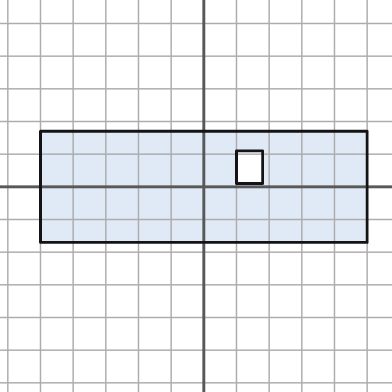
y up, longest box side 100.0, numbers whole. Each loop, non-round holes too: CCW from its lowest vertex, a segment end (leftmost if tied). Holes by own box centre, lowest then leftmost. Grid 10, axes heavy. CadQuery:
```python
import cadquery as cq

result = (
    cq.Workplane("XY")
    .moveTo(-50.0, -17.0)
    .lineTo(50.0, -17.0)
    .lineTo(50.0, 17.0)
    .lineTo(-50.0, 17.0)
    .close()
    .moveTo(10.0, 1.0)
    .lineTo(18.0, 1.0)
    .lineTo(18.0, 11.0)
    .lineTo(10.0, 11.0)
    .close()
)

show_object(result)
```